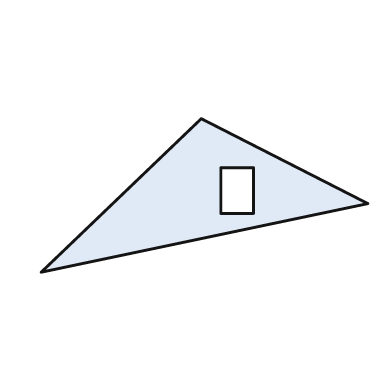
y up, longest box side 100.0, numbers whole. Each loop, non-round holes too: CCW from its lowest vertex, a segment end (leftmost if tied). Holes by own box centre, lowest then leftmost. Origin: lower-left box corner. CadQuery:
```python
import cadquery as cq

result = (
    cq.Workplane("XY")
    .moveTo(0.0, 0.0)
    .lineTo(100.0, 21.0)
    .lineTo(49.0, 47.0)
    .close()
    .moveTo(55.0, 18.0)
    .lineTo(65.0, 18.0)
    .lineTo(65.0, 32.0)
    .lineTo(55.0, 32.0)
    .close()
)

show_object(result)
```